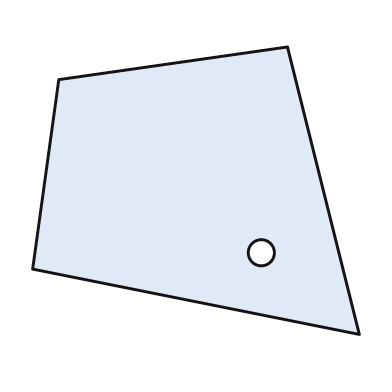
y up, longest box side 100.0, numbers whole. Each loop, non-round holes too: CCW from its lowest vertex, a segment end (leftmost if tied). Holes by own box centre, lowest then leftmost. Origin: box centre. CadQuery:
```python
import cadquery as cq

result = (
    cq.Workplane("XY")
    .moveTo(50.0, -44.0)
    .lineTo(28.0, 44.0)
    .lineTo(-42.0, 34.0)
    .lineTo(-50.0, -24.0)
    .close()
    .moveTo(20.0, -19.0)
    .circle(4.0)
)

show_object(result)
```